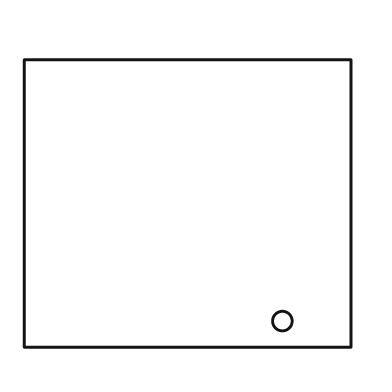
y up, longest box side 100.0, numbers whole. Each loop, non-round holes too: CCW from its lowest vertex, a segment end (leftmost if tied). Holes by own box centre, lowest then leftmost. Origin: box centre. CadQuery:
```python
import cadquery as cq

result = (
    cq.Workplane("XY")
    .moveTo(-50.0, -44.0)
    .lineTo(50.0, -44.0)
    .lineTo(50.0, 44.0)
    .lineTo(-50.0, 44.0)
    .close()
    .moveTo(29.0, -36.0)
    .circle(3.0)
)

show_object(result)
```